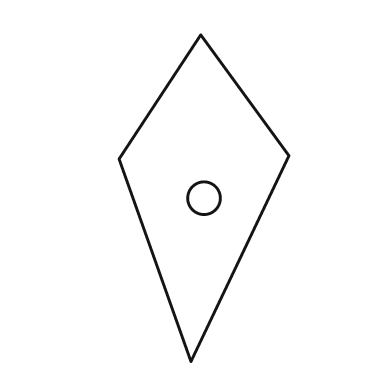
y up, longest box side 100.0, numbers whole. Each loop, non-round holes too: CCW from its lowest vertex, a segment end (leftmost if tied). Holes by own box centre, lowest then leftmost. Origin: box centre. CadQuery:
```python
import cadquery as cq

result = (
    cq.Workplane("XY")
    .moveTo(-4.0, -50.0)
    .lineTo(26.0, 13.0)
    .lineTo(-1.0, 50.0)
    .lineTo(-26.0, 12.0)
    .close()
    .moveTo(0.0, 0.0)
    .circle(5.0)
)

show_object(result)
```